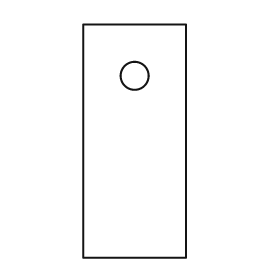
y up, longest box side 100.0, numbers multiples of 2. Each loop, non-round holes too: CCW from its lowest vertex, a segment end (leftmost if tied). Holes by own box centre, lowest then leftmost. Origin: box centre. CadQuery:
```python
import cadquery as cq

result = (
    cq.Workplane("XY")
    .moveTo(-22.0, -50.0)
    .lineTo(22.0, -50.0)
    .lineTo(22.0, 50.0)
    .lineTo(-22.0, 50.0)
    .close()
    .moveTo(0.0, 28.0)
    .circle(6.0)
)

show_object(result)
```